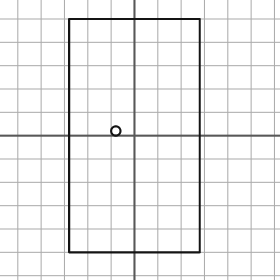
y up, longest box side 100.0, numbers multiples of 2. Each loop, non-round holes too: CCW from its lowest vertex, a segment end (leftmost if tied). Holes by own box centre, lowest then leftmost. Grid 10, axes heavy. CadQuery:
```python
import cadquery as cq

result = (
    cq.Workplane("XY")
    .moveTo(-28.0, -50.0)
    .lineTo(28.0, -50.0)
    .lineTo(28.0, 50.0)
    .lineTo(-28.0, 50.0)
    .close()
    .moveTo(-8.0, 2.0)
    .circle(2.0)
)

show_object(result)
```